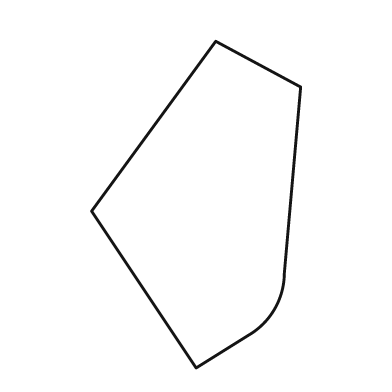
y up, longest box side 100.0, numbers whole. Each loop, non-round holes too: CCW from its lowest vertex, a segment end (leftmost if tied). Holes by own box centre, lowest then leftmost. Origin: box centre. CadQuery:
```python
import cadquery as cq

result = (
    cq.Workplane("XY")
    .moveTo(0.0, -50.0)
    .lineTo(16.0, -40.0)
    .threePointArc((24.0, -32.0), (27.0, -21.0))
    .lineTo(32.0, 36.0)
    .lineTo(6.0, 50.0)
    .lineTo(-32.0, -2.0)
    .close()
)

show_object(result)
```